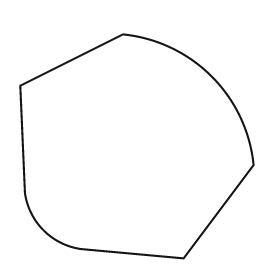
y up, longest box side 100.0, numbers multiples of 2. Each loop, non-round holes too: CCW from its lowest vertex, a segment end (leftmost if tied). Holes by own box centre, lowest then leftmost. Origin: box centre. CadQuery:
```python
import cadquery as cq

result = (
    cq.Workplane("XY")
    .moveTo(20.0, -48.0)
    .lineTo(50.0, -8.0)
    .threePointArc((32.0, 30.0), (-6.0, 48.0))
    .lineTo(-50.0, 26.0)
    .lineTo(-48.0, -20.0)
    .threePointArc((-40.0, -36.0), (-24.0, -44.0))
    .close()
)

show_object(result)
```